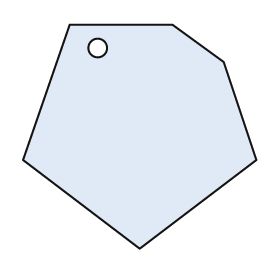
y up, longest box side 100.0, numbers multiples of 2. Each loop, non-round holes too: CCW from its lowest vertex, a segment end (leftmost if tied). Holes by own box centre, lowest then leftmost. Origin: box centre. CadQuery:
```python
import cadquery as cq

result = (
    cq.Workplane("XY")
    .moveTo(0.0, -48.0)
    .lineTo(50.0, -10.0)
    .lineTo(36.0, 32.0)
    .lineTo(14.0, 48.0)
    .lineTo(-30.0, 48.0)
    .lineTo(-50.0, -10.0)
    .close()
    .moveTo(-18.0, 38.0)
    .circle(4.0)
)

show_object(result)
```